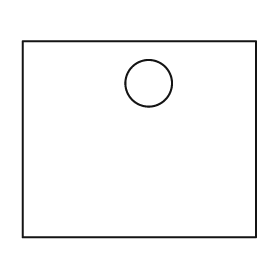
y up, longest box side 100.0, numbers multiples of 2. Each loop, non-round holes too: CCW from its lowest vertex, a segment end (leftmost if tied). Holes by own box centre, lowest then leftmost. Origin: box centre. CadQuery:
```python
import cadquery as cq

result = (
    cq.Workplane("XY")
    .moveTo(-50.0, -42.0)
    .lineTo(50.0, -42.0)
    .lineTo(50.0, 42.0)
    .lineTo(-50.0, 42.0)
    .close()
    .moveTo(4.0, 24.0)
    .circle(10.0)
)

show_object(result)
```